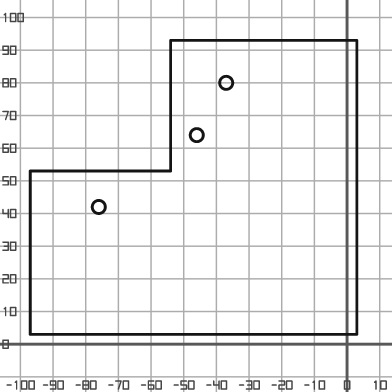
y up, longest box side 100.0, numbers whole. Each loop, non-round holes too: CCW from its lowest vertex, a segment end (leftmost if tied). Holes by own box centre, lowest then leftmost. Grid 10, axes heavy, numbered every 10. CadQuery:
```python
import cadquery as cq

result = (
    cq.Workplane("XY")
    .moveTo(-97.0, 3.0)
    .lineTo(3.0, 3.0)
    .lineTo(3.0, 93.0)
    .lineTo(-54.0, 93.0)
    .lineTo(-54.0, 53.0)
    .lineTo(-97.0, 53.0)
    .close()
    .moveTo(-76.0, 42.0)
    .circle(2.0)
    .moveTo(-46.0, 64.0)
    .circle(2.0)
    .moveTo(-37.0, 80.0)
    .circle(2.0)
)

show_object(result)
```